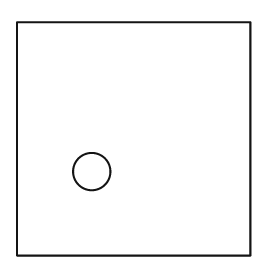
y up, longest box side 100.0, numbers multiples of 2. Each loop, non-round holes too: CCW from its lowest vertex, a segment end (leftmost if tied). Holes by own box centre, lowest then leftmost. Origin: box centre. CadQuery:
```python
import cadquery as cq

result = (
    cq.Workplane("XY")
    .moveTo(-50.0, -50.0)
    .lineTo(50.0, -50.0)
    .lineTo(50.0, 50.0)
    .lineTo(-50.0, 50.0)
    .close()
    .moveTo(-18.0, -14.0)
    .circle(8.0)
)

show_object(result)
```